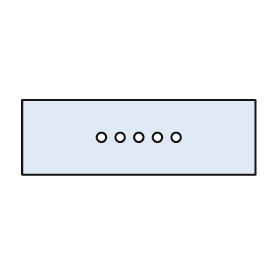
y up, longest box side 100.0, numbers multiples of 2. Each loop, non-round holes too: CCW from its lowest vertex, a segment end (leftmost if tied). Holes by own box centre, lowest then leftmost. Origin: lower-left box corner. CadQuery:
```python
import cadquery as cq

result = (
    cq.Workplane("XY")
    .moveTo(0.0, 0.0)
    .lineTo(100.0, 0.0)
    .lineTo(100.0, 32.0)
    .lineTo(0.0, 32.0)
    .close()
    .moveTo(34.0, 16.0)
    .circle(2.0)
    .moveTo(42.0, 16.0)
    .circle(2.0)
    .moveTo(50.0, 16.0)
    .circle(2.0)
    .moveTo(58.0, 16.0)
    .circle(2.0)
    .moveTo(66.0, 16.0)
    .circle(2.0)
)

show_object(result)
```